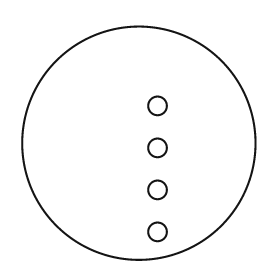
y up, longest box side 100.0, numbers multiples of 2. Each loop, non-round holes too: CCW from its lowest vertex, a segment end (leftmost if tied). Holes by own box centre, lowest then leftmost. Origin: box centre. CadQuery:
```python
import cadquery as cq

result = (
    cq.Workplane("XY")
    .moveTo(0.0, 0.0)
    .circle(50.0)
    .moveTo(8.0, -38.0)
    .circle(4.0)
    .moveTo(8.0, -20.0)
    .circle(4.0)
    .moveTo(8.0, -2.0)
    .circle(4.0)
    .moveTo(8.0, 16.0)
    .circle(4.0)
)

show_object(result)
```